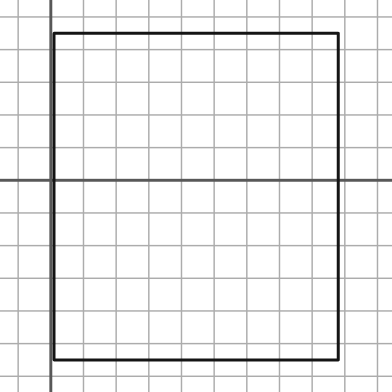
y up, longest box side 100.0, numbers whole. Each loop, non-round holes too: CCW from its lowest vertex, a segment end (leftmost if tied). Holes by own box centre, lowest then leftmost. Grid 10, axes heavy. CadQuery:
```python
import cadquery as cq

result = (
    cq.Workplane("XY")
    .moveTo(1.0, -55.0)
    .lineTo(88.0, -55.0)
    .lineTo(88.0, 45.0)
    .lineTo(1.0, 45.0)
    .close()
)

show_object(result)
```